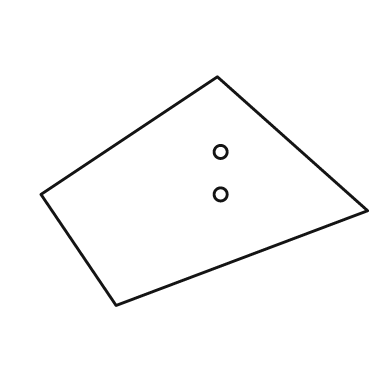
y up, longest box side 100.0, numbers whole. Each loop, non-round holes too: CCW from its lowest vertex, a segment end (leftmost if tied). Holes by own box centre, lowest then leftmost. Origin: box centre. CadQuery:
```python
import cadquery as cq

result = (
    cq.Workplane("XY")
    .moveTo(-27.0, -35.0)
    .lineTo(50.0, -6.0)
    .lineTo(4.0, 35.0)
    .lineTo(-50.0, -1.0)
    .close()
    .moveTo(5.0, -1.0)
    .circle(2.0)
    .moveTo(5.0, 12.0)
    .circle(2.0)
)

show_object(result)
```